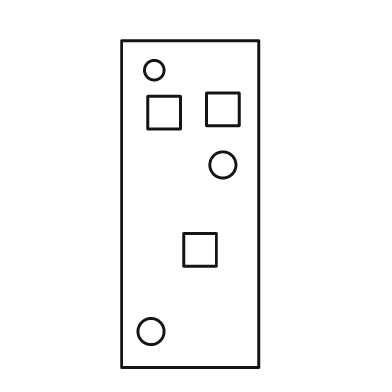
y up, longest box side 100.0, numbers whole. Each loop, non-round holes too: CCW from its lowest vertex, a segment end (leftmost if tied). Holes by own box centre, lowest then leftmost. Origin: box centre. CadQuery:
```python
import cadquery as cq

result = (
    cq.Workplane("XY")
    .moveTo(-21.0, -50.0)
    .lineTo(21.0, -50.0)
    .lineTo(21.0, 50.0)
    .lineTo(-21.0, 50.0)
    .close()
    .moveTo(-12.0, -39.0)
    .circle(4.0)
    .moveTo(-2.0, -19.0)
    .lineTo(8.0, -19.0)
    .lineTo(8.0, -9.0)
    .lineTo(-2.0, -9.0)
    .close()
    .moveTo(10.0, 12.0)
    .circle(4.0)
    .moveTo(-13.0, 23.0)
    .lineTo(-3.0, 23.0)
    .lineTo(-3.0, 33.0)
    .lineTo(-13.0, 33.0)
    .close()
    .moveTo(5.0, 24.0)
    .lineTo(15.0, 24.0)
    .lineTo(15.0, 34.0)
    .lineTo(5.0, 34.0)
    .close()
    .moveTo(-11.0, 41.0)
    .circle(3.0)
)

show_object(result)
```